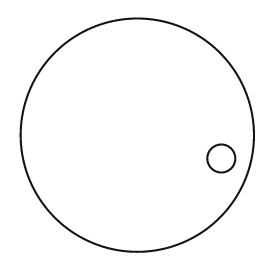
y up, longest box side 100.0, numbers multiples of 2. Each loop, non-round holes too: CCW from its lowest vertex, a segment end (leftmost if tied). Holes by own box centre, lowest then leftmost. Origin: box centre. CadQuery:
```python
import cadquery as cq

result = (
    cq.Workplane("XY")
    .moveTo(0.0, 0.0)
    .circle(50.0)
    .moveTo(36.0, -10.0)
    .circle(6.0)
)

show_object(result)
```